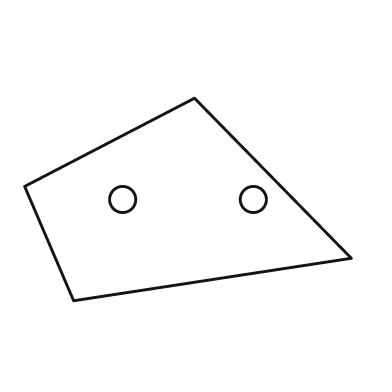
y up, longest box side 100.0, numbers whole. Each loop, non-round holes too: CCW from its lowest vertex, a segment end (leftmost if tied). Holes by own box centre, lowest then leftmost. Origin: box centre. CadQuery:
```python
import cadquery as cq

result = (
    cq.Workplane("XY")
    .moveTo(-35.0, -31.0)
    .lineTo(50.0, -18.0)
    .lineTo(2.0, 31.0)
    .lineTo(-50.0, 4.0)
    .close()
    .moveTo(-20.0, 0.0)
    .circle(4.0)
    .moveTo(20.0, 0.0)
    .circle(4.0)
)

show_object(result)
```